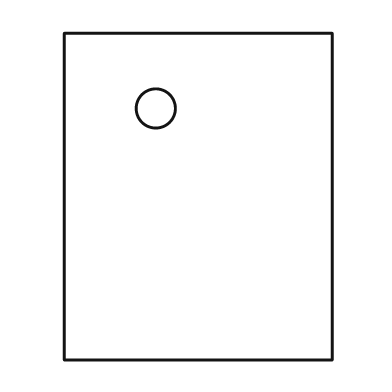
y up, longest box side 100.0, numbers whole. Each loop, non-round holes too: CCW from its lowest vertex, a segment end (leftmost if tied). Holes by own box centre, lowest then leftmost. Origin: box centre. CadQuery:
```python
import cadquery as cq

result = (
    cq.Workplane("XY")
    .moveTo(-41.0, -50.0)
    .lineTo(41.0, -50.0)
    .lineTo(41.0, 50.0)
    .lineTo(-41.0, 50.0)
    .close()
    .moveTo(-13.0, 27.0)
    .circle(6.0)
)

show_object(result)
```